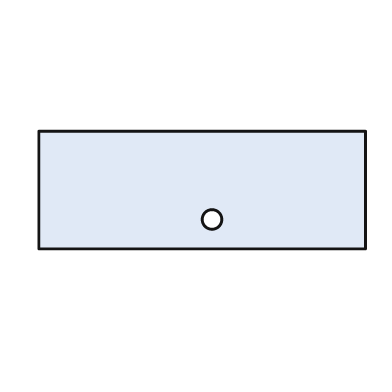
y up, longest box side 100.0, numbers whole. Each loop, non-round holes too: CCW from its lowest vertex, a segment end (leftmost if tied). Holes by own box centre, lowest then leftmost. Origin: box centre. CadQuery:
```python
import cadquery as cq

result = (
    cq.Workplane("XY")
    .moveTo(-50.0, -18.0)
    .lineTo(50.0, -18.0)
    .lineTo(50.0, 18.0)
    .lineTo(-50.0, 18.0)
    .close()
    .moveTo(3.0, -9.0)
    .circle(3.0)
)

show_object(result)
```